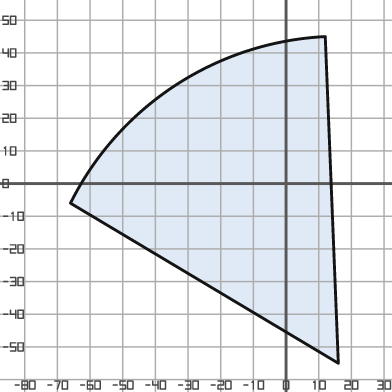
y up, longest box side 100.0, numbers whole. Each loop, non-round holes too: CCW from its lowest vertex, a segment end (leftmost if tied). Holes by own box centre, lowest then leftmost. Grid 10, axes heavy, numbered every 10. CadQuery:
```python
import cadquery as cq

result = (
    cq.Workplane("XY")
    .moveTo(16.0, -55.0)
    .lineTo(12.0, 45.0)
    .threePointArc((-34.0, 30.0), (-66.0, -6.0))
    .close()
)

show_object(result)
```